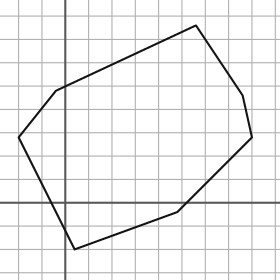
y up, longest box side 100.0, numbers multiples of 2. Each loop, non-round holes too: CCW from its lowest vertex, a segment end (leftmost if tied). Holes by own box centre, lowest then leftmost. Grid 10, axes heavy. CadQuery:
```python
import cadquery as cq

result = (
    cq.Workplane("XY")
    .moveTo(4.0, -20.0)
    .lineTo(48.0, -4.0)
    .lineTo(80.0, 28.0)
    .lineTo(76.0, 46.0)
    .lineTo(56.0, 76.0)
    .lineTo(-4.0, 48.0)
    .lineTo(-20.0, 28.0)
    .close()
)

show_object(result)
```